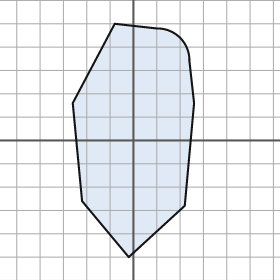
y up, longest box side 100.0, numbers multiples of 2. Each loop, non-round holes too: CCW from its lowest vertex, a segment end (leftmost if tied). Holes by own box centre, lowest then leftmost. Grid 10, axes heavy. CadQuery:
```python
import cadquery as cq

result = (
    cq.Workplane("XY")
    .moveTo(-2.0, -50.0)
    .lineTo(22.0, -28.0)
    .lineTo(26.0, 16.0)
    .lineTo(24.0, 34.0)
    .threePointArc((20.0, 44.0), (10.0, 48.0))
    .lineTo(-8.0, 50.0)
    .lineTo(-26.0, 16.0)
    .lineTo(-22.0, -26.0)
    .close()
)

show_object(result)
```